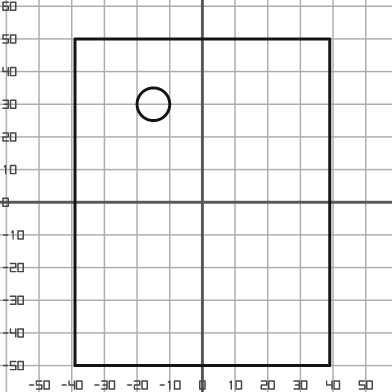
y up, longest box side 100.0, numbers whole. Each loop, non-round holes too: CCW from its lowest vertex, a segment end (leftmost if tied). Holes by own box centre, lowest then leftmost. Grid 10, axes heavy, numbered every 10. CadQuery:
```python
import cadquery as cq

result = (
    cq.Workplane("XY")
    .moveTo(-39.0, -50.0)
    .lineTo(39.0, -50.0)
    .lineTo(39.0, 50.0)
    .lineTo(-39.0, 50.0)
    .close()
    .moveTo(-15.0, 30.0)
    .circle(5.0)
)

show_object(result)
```